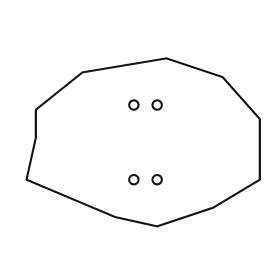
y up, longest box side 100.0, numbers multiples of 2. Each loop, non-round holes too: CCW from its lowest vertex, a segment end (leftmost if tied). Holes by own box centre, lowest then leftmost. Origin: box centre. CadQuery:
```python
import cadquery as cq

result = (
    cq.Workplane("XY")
    .moveTo(6.0, -36.0)
    .lineTo(30.0, -28.0)
    .lineTo(50.0, -16.0)
    .lineTo(50.0, 10.0)
    .lineTo(34.0, 28.0)
    .lineTo(10.0, 36.0)
    .lineTo(-26.0, 30.0)
    .lineTo(-46.0, 14.0)
    .lineTo(-46.0, 2.0)
    .lineTo(-50.0, -16.0)
    .lineTo(-12.0, -32.0)
    .close()
    .moveTo(-4.0, -16.0)
    .circle(2.0)
    .moveTo(6.0, -16.0)
    .circle(2.0)
    .moveTo(-4.0, 16.0)
    .circle(2.0)
    .moveTo(6.0, 16.0)
    .circle(2.0)
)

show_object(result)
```